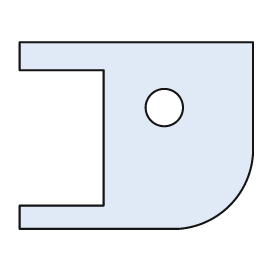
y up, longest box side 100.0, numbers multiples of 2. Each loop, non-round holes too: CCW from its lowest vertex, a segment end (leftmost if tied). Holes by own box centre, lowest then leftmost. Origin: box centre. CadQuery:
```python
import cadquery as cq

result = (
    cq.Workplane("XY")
    .moveTo(-50.0, -40.0)
    .lineTo(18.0, -40.0)
    .threePointArc((40.0, -30.0), (50.0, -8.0))
    .lineTo(50.0, 40.0)
    .lineTo(-50.0, 40.0)
    .lineTo(-50.0, 28.0)
    .lineTo(-14.0, 28.0)
    .lineTo(-14.0, -30.0)
    .lineTo(-50.0, -30.0)
    .close()
    .moveTo(12.0, 12.0)
    .circle(8.0)
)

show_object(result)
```